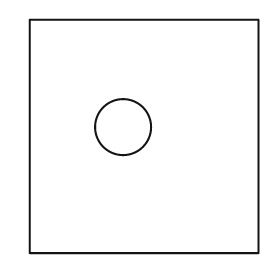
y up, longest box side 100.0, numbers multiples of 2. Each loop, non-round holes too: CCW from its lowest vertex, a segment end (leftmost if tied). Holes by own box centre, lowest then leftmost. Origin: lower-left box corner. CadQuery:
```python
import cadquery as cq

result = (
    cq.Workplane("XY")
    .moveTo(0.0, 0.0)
    .lineTo(98.0, 0.0)
    .lineTo(98.0, 100.0)
    .lineTo(0.0, 100.0)
    .close()
    .moveTo(40.0, 54.0)
    .circle(12.0)
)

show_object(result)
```